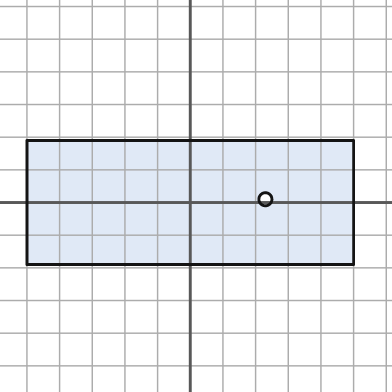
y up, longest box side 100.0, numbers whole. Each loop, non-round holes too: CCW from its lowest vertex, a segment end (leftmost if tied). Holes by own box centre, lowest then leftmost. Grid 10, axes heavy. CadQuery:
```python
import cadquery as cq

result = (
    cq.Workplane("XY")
    .moveTo(-50.0, -19.0)
    .lineTo(50.0, -19.0)
    .lineTo(50.0, 19.0)
    .lineTo(-50.0, 19.0)
    .close()
    .moveTo(23.0, 1.0)
    .circle(2.0)
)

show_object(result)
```